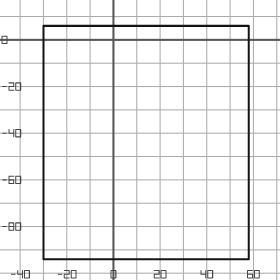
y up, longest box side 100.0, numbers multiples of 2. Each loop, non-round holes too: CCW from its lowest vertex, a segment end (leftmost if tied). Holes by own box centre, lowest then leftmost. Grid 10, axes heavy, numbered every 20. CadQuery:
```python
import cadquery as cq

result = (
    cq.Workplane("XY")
    .moveTo(-30.0, -94.0)
    .lineTo(58.0, -94.0)
    .lineTo(58.0, 6.0)
    .lineTo(-30.0, 6.0)
    .close()
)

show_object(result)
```